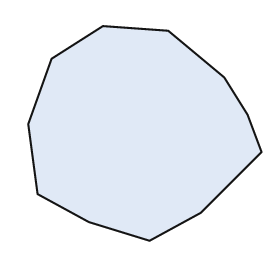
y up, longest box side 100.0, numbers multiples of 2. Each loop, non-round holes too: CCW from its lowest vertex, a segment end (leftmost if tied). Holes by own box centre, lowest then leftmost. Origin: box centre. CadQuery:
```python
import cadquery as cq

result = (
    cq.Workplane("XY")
    .moveTo(2.0, -46.0)
    .lineTo(24.0, -34.0)
    .lineTo(50.0, -8.0)
    .lineTo(44.0, 8.0)
    .lineTo(34.0, 24.0)
    .lineTo(10.0, 44.0)
    .lineTo(-18.0, 46.0)
    .lineTo(-40.0, 32.0)
    .lineTo(-50.0, 4.0)
    .lineTo(-46.0, -26.0)
    .lineTo(-24.0, -38.0)
    .close()
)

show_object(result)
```